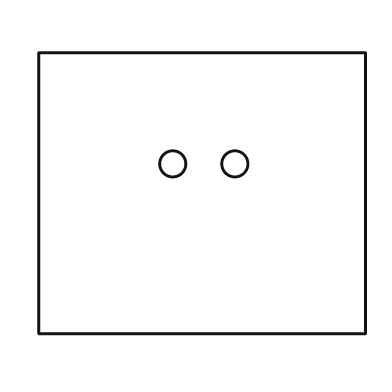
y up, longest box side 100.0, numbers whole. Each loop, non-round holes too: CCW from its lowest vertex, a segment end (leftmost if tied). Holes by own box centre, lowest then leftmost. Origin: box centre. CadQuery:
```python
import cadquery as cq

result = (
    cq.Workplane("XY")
    .moveTo(-50.0, -43.0)
    .lineTo(50.0, -43.0)
    .lineTo(50.0, 43.0)
    .lineTo(-50.0, 43.0)
    .close()
    .moveTo(-9.0, 9.0)
    .circle(4.0)
    .moveTo(10.0, 9.0)
    .circle(4.0)
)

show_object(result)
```